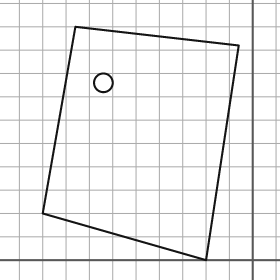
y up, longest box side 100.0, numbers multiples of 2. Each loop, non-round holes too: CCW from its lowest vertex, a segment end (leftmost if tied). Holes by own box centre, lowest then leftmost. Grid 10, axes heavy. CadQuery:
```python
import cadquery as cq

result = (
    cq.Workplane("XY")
    .moveTo(-20.0, 0.0)
    .lineTo(-6.0, 92.0)
    .lineTo(-76.0, 100.0)
    .lineTo(-90.0, 20.0)
    .close()
    .moveTo(-64.0, 76.0)
    .circle(4.0)
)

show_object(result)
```